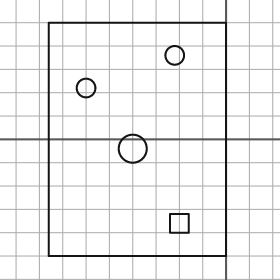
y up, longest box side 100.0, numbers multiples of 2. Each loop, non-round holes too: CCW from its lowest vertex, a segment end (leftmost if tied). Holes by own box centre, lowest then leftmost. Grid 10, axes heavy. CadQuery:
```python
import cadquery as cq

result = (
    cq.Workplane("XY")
    .moveTo(-76.0, -50.0)
    .lineTo(0.0, -50.0)
    .lineTo(0.0, 50.0)
    .lineTo(-76.0, 50.0)
    .close()
    .moveTo(-24.0, -40.0)
    .lineTo(-16.0, -40.0)
    .lineTo(-16.0, -32.0)
    .lineTo(-24.0, -32.0)
    .close()
    .moveTo(-40.0, -4.0)
    .circle(6.0)
    .moveTo(-60.0, 22.0)
    .circle(4.0)
    .moveTo(-22.0, 36.0)
    .circle(4.0)
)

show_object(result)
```